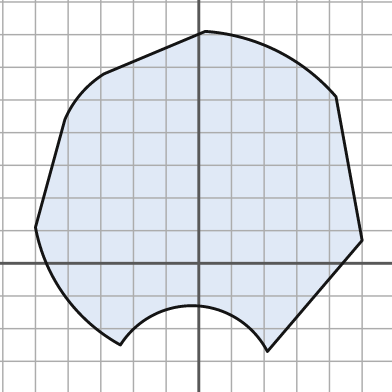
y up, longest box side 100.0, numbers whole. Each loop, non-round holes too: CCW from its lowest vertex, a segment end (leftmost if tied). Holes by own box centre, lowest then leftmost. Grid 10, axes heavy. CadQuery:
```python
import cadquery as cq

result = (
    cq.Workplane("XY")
    .moveTo(21.0, -27.0)
    .lineTo(50.0, 7.0)
    .lineTo(42.0, 51.0)
    .threePointArc((24.0, 65.0), (2.0, 71.0))
    .lineTo(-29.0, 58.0)
    .threePointArc((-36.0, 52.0), (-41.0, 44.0))
    .lineTo(-50.0, 11.0)
    .threePointArc((-41.0, -10.0), (-24.0, -25.0))
    .threePointArc((-1.0, -13.0), (21.0, -27.0))
    .close()
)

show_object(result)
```